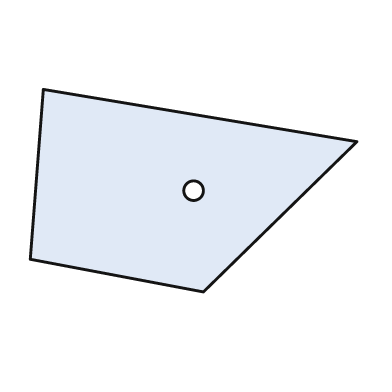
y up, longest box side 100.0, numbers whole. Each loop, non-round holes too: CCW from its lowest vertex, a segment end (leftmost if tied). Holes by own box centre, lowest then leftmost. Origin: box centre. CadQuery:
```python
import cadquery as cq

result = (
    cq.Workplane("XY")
    .moveTo(3.0, -31.0)
    .lineTo(50.0, 15.0)
    .lineTo(-46.0, 31.0)
    .lineTo(-50.0, -21.0)
    .close()
    .moveTo(0.0, 0.0)
    .circle(3.0)
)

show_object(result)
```